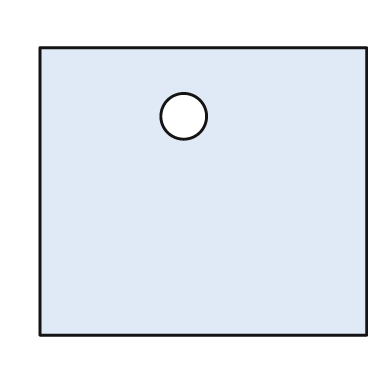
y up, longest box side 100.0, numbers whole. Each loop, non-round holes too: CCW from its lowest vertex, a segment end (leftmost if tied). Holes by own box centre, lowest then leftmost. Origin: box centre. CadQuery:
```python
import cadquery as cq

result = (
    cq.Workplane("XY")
    .moveTo(-50.0, -44.0)
    .lineTo(50.0, -44.0)
    .lineTo(50.0, 44.0)
    .lineTo(-50.0, 44.0)
    .close()
    .moveTo(-6.0, 23.0)
    .circle(7.0)
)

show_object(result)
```